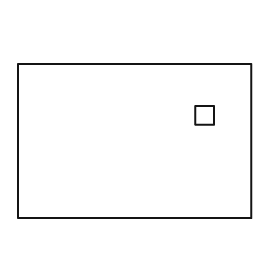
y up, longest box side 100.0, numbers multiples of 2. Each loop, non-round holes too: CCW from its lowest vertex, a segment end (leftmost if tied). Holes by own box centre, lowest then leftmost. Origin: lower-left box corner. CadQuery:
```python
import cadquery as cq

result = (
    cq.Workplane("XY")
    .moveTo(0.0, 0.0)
    .lineTo(100.0, 0.0)
    .lineTo(100.0, 66.0)
    .lineTo(0.0, 66.0)
    .close()
    .moveTo(76.0, 40.0)
    .lineTo(84.0, 40.0)
    .lineTo(84.0, 48.0)
    .lineTo(76.0, 48.0)
    .close()
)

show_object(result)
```